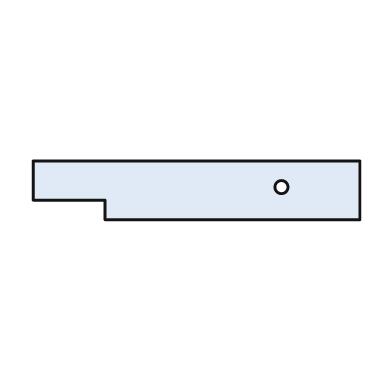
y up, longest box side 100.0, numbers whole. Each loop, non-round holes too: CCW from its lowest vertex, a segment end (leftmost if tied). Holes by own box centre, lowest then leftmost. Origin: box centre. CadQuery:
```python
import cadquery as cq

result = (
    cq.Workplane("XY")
    .moveTo(-28.0, -9.0)
    .lineTo(50.0, -9.0)
    .lineTo(50.0, 9.0)
    .lineTo(-50.0, 9.0)
    .lineTo(-50.0, -3.0)
    .lineTo(-28.0, -3.0)
    .close()
    .moveTo(26.0, 1.0)
    .circle(2.0)
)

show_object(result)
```